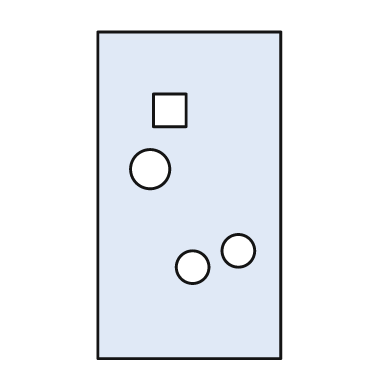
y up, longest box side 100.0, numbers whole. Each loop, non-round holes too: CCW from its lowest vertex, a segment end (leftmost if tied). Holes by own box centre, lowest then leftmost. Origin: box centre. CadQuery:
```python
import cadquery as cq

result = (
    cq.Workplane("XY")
    .moveTo(-28.0, -50.0)
    .lineTo(28.0, -50.0)
    .lineTo(28.0, 50.0)
    .lineTo(-28.0, 50.0)
    .close()
    .moveTo(1.0, -22.0)
    .circle(5.0)
    .moveTo(15.0, -17.0)
    .circle(5.0)
    .moveTo(-12.0, 8.0)
    .circle(6.0)
    .moveTo(-11.0, 21.0)
    .lineTo(-1.0, 21.0)
    .lineTo(-1.0, 31.0)
    .lineTo(-11.0, 31.0)
    .close()
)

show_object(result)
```